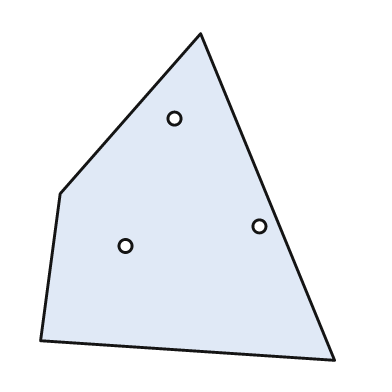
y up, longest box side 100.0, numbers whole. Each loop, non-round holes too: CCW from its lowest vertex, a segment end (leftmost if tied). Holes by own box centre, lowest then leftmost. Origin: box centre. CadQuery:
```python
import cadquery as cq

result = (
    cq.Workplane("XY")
    .moveTo(45.0, -50.0)
    .lineTo(4.0, 50.0)
    .lineTo(-39.0, 1.0)
    .lineTo(-45.0, -44.0)
    .close()
    .moveTo(-19.0, -15.0)
    .circle(2.0)
    .moveTo(22.0, -9.0)
    .circle(2.0)
    .moveTo(-4.0, 24.0)
    .circle(2.0)
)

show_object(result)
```